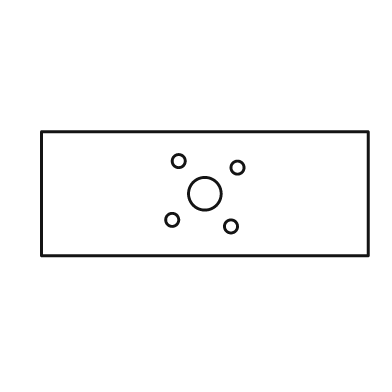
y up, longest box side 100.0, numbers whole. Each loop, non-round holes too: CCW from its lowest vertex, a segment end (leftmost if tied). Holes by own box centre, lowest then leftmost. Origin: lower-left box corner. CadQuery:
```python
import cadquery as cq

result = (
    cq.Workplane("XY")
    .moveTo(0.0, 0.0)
    .lineTo(100.0, 0.0)
    .lineTo(100.0, 38.0)
    .lineTo(0.0, 38.0)
    .close()
    .moveTo(58.0, 9.0)
    .circle(2.0)
    .moveTo(40.0, 11.0)
    .circle(2.0)
    .moveTo(50.0, 19.0)
    .circle(5.0)
    .moveTo(60.0, 27.0)
    .circle(2.0)
    .moveTo(42.0, 29.0)
    .circle(2.0)
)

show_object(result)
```